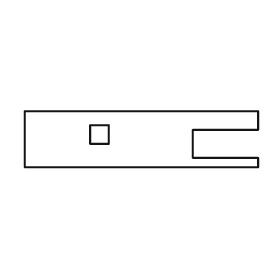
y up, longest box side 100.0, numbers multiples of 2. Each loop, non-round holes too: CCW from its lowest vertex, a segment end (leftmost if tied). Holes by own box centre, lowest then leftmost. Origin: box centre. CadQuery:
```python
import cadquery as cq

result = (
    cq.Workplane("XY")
    .moveTo(-50.0, -12.0)
    .lineTo(50.0, -12.0)
    .lineTo(50.0, -8.0)
    .lineTo(22.0, -8.0)
    .lineTo(22.0, 4.0)
    .lineTo(50.0, 4.0)
    .lineTo(50.0, 12.0)
    .lineTo(-50.0, 12.0)
    .close()
    .moveTo(-22.0, -2.0)
    .lineTo(-14.0, -2.0)
    .lineTo(-14.0, 6.0)
    .lineTo(-22.0, 6.0)
    .close()
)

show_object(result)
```